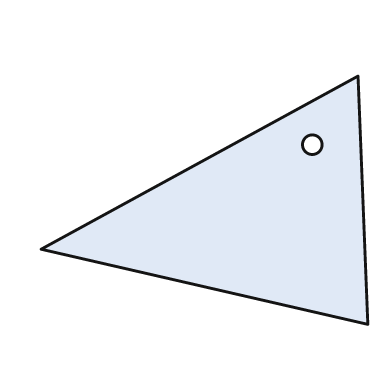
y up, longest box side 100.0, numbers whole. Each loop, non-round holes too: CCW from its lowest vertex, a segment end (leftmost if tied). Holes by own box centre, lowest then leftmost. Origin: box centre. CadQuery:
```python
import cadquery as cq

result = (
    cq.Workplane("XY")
    .moveTo(50.0, -38.0)
    .lineTo(47.0, 38.0)
    .lineTo(-50.0, -15.0)
    .close()
    .moveTo(33.0, 17.0)
    .circle(3.0)
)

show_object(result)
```